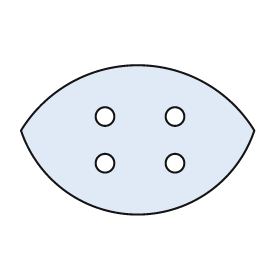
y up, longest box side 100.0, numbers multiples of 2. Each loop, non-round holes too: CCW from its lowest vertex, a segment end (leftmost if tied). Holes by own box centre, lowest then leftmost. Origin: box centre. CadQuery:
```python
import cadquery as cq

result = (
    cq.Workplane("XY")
    .moveTo(-50.0, 4.0)
    .threePointArc((0.0, -32.0), (50.0, 4.0))
    .threePointArc((0.0, 32.0), (-50.0, 4.0))
    .close()
    .moveTo(-14.0, -10.0)
    .circle(4.0)
    .moveTo(16.0, -10.0)
    .circle(4.0)
    .moveTo(-14.0, 10.0)
    .circle(4.0)
    .moveTo(16.0, 10.0)
    .circle(4.0)
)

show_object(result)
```